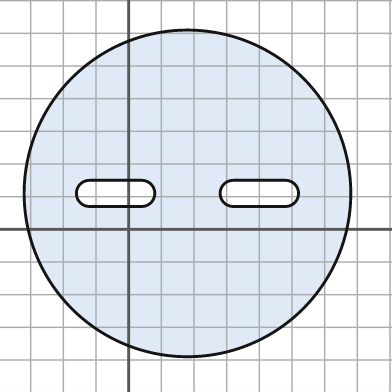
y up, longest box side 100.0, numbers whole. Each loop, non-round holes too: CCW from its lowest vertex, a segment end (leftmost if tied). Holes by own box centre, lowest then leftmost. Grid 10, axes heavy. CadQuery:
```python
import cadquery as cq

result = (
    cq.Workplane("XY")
    .moveTo(18.0, 11.0)
    .circle(50.0)
    .moveTo(-12.0, 7.0)
    .lineTo(4.0, 7.0)
    .threePointArc((8.0, 11.0), (4.0, 15.0))
    .lineTo(-12.0, 15.0)
    .threePointArc((-16.0, 11.0), (-12.0, 7.0))
    .close()
    .moveTo(32.0, 7.0)
    .lineTo(48.0, 7.0)
    .threePointArc((52.0, 11.0), (48.0, 15.0))
    .lineTo(32.0, 15.0)
    .threePointArc((28.0, 11.0), (32.0, 7.0))
    .close()
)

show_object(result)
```